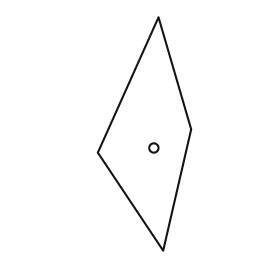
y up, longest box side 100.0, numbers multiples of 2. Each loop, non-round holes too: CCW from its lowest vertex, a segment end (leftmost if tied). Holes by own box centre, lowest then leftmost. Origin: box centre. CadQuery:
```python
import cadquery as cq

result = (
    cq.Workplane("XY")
    .moveTo(8.0, -50.0)
    .lineTo(20.0, 2.0)
    .lineTo(6.0, 50.0)
    .lineTo(-20.0, -8.0)
    .close()
    .moveTo(4.0, -6.0)
    .circle(2.0)
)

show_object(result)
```